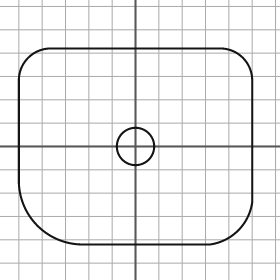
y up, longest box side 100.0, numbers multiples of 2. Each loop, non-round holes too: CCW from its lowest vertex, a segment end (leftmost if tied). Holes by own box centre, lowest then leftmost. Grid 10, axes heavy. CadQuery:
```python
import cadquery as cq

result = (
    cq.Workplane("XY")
    .moveTo(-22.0, -42.0)
    .lineTo(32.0, -42.0)
    .threePointArc((44.0, -36.0), (50.0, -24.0))
    .lineTo(50.0, 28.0)
    .threePointArc((46.0, 38.0), (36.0, 42.0))
    .lineTo(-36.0, 42.0)
    .threePointArc((-46.0, 38.0), (-50.0, 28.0))
    .lineTo(-50.0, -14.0)
    .threePointArc((-42.0, -34.0), (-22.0, -42.0))
    .close()
    .moveTo(0.0, 0.0)
    .circle(8.0)
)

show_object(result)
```